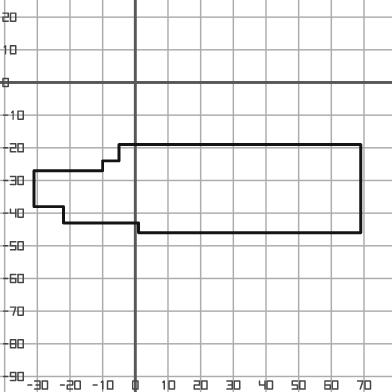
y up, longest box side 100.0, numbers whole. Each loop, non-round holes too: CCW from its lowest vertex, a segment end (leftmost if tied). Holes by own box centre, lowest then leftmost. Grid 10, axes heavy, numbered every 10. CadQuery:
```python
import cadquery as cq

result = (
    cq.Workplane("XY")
    .moveTo(1.0, -46.0)
    .lineTo(69.0, -46.0)
    .lineTo(69.0, -19.0)
    .lineTo(-5.0, -19.0)
    .lineTo(-5.0, -24.0)
    .lineTo(-10.0, -24.0)
    .lineTo(-10.0, -27.0)
    .lineTo(-31.0, -27.0)
    .lineTo(-31.0, -38.0)
    .lineTo(-22.0, -38.0)
    .lineTo(-22.0, -43.0)
    .lineTo(1.0, -43.0)
    .close()
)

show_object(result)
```